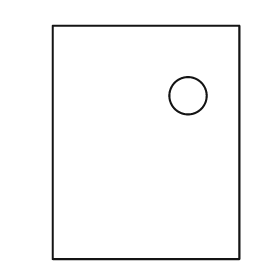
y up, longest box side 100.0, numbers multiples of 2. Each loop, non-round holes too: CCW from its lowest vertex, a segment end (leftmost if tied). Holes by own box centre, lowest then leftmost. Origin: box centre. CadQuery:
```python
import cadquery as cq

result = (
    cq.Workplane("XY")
    .moveTo(-40.0, -50.0)
    .lineTo(40.0, -50.0)
    .lineTo(40.0, 50.0)
    .lineTo(-40.0, 50.0)
    .close()
    .moveTo(18.0, 20.0)
    .circle(8.0)
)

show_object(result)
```